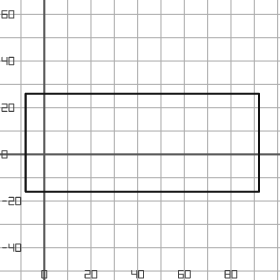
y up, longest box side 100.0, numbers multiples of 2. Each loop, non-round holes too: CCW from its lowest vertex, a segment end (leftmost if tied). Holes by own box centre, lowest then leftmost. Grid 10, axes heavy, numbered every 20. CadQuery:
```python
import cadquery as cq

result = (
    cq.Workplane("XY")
    .moveTo(-8.0, -16.0)
    .lineTo(92.0, -16.0)
    .lineTo(92.0, 26.0)
    .lineTo(-8.0, 26.0)
    .close()
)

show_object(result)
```